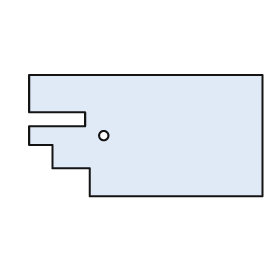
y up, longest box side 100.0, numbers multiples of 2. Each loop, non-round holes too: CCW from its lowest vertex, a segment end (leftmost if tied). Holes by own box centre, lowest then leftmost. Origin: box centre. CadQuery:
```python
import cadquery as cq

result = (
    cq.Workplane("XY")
    .moveTo(-24.0, -26.0)
    .lineTo(50.0, -26.0)
    .lineTo(50.0, 26.0)
    .lineTo(-50.0, 26.0)
    .lineTo(-50.0, 10.0)
    .lineTo(-26.0, 10.0)
    .lineTo(-26.0, 4.0)
    .lineTo(-50.0, 4.0)
    .lineTo(-50.0, -4.0)
    .lineTo(-40.0, -4.0)
    .lineTo(-40.0, -14.0)
    .lineTo(-24.0, -14.0)
    .close()
    .moveTo(-18.0, 0.0)
    .circle(2.0)
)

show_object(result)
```